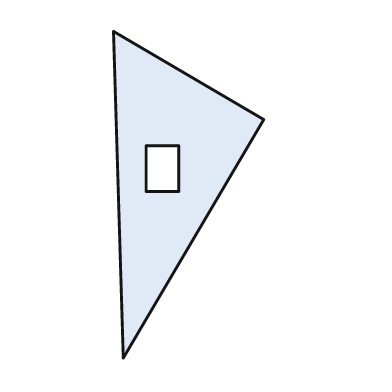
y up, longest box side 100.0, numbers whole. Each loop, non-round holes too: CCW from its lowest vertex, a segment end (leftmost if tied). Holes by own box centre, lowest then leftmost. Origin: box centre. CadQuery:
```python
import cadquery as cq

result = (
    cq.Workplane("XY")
    .moveTo(-20.0, -50.0)
    .lineTo(23.0, 23.0)
    .lineTo(-23.0, 50.0)
    .close()
    .moveTo(-13.0, 1.0)
    .lineTo(-3.0, 1.0)
    .lineTo(-3.0, 15.0)
    .lineTo(-13.0, 15.0)
    .close()
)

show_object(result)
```